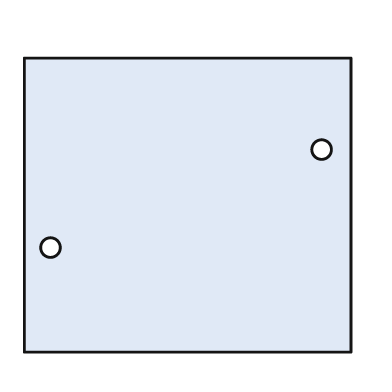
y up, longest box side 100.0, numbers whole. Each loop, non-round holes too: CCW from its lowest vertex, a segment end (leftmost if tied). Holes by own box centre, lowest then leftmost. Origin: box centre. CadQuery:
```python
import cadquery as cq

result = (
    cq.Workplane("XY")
    .moveTo(-50.0, -45.0)
    .lineTo(50.0, -45.0)
    .lineTo(50.0, 45.0)
    .lineTo(-50.0, 45.0)
    .close()
    .moveTo(-42.0, -13.0)
    .circle(3.0)
    .moveTo(41.0, 17.0)
    .circle(3.0)
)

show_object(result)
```